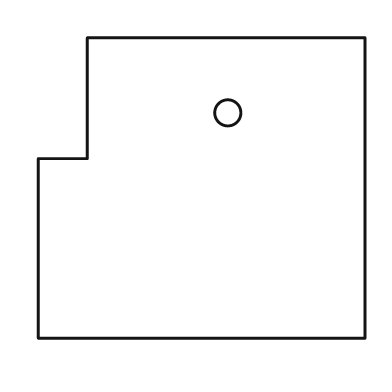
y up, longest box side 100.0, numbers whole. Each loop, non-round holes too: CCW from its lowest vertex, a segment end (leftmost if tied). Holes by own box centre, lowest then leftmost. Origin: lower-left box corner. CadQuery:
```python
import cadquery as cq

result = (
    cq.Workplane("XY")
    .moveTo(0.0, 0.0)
    .lineTo(100.0, 0.0)
    .lineTo(100.0, 92.0)
    .lineTo(15.0, 92.0)
    .lineTo(15.0, 55.0)
    .lineTo(0.0, 55.0)
    .close()
    .moveTo(58.0, 69.0)
    .circle(4.0)
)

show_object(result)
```